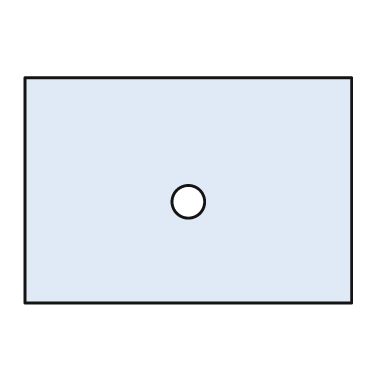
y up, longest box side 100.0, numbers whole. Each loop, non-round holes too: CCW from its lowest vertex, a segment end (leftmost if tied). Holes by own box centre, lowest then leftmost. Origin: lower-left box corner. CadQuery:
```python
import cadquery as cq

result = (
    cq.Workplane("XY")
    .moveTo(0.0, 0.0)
    .lineTo(100.0, 0.0)
    .lineTo(100.0, 69.0)
    .lineTo(0.0, 69.0)
    .close()
    .moveTo(50.0, 31.0)
    .circle(5.0)
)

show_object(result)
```